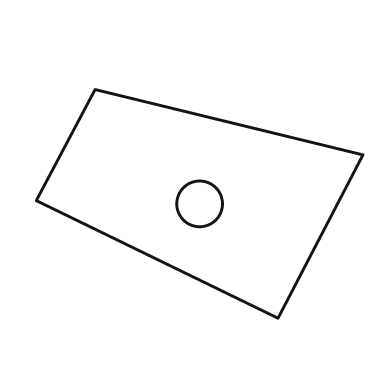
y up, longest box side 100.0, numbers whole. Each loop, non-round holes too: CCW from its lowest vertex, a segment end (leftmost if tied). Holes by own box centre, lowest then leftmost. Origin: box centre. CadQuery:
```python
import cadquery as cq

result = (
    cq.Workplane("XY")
    .moveTo(24.0, -35.0)
    .lineTo(50.0, 15.0)
    .lineTo(-32.0, 35.0)
    .lineTo(-50.0, 1.0)
    .close()
    .moveTo(0.0, 0.0)
    .circle(7.0)
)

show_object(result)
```